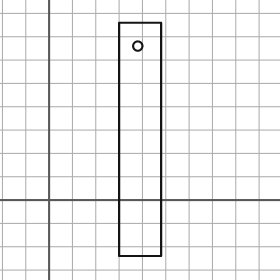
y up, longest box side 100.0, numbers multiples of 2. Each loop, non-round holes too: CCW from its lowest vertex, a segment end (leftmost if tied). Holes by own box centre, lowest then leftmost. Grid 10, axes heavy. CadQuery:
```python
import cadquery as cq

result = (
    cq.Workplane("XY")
    .moveTo(30.0, -24.0)
    .lineTo(48.0, -24.0)
    .lineTo(48.0, 76.0)
    .lineTo(30.0, 76.0)
    .close()
    .moveTo(38.0, 66.0)
    .circle(2.0)
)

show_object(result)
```